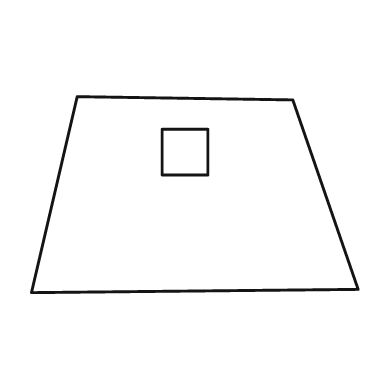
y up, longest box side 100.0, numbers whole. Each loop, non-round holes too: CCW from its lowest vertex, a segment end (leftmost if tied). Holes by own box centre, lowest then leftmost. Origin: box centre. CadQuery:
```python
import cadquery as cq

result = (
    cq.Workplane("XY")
    .moveTo(-50.0, -30.0)
    .lineTo(50.0, -29.0)
    .lineTo(30.0, 29.0)
    .lineTo(-36.0, 30.0)
    .close()
    .moveTo(-10.0, 6.0)
    .lineTo(4.0, 6.0)
    .lineTo(4.0, 20.0)
    .lineTo(-10.0, 20.0)
    .close()
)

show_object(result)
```